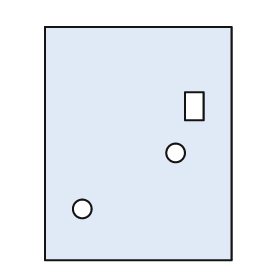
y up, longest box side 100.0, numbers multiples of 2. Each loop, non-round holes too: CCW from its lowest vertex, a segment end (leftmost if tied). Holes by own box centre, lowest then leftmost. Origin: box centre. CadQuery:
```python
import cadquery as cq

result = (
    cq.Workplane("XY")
    .moveTo(-40.0, -50.0)
    .lineTo(40.0, -50.0)
    .lineTo(40.0, 50.0)
    .lineTo(-40.0, 50.0)
    .close()
    .moveTo(-24.0, -28.0)
    .circle(4.0)
    .moveTo(16.0, -4.0)
    .circle(4.0)
    .moveTo(20.0, 10.0)
    .lineTo(28.0, 10.0)
    .lineTo(28.0, 22.0)
    .lineTo(20.0, 22.0)
    .close()
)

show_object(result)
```